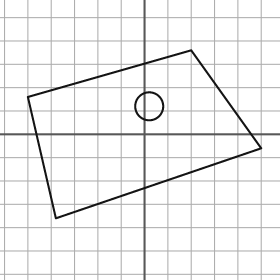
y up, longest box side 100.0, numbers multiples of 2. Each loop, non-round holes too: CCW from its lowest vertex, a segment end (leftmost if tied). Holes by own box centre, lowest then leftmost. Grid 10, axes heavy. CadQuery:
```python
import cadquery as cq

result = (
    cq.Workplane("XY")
    .moveTo(-38.0, -36.0)
    .lineTo(50.0, -6.0)
    .lineTo(20.0, 36.0)
    .lineTo(-50.0, 16.0)
    .close()
    .moveTo(2.0, 12.0)
    .circle(6.0)
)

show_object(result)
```